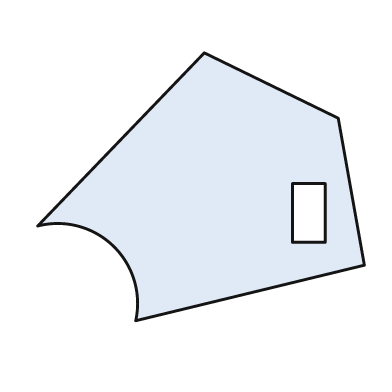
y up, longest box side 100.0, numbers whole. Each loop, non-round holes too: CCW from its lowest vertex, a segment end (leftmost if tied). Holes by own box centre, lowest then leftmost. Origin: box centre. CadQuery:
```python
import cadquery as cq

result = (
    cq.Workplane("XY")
    .moveTo(-20.0, -41.0)
    .lineTo(50.0, -24.0)
    .lineTo(42.0, 21.0)
    .lineTo(1.0, 41.0)
    .lineTo(-50.0, -12.0)
    .threePointArc((-27.0, -18.0), (-20.0, -41.0))
    .close()
    .moveTo(28.0, -17.0)
    .lineTo(38.0, -17.0)
    .lineTo(38.0, 1.0)
    .lineTo(28.0, 1.0)
    .close()
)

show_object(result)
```